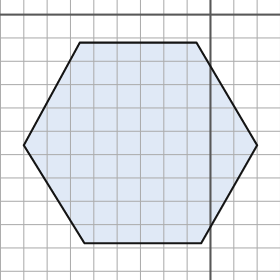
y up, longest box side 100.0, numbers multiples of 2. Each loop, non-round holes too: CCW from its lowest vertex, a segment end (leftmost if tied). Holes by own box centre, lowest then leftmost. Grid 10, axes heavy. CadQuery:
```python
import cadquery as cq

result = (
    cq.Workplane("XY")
    .moveTo(-54.0, -98.0)
    .lineTo(-4.0, -98.0)
    .lineTo(20.0, -56.0)
    .lineTo(-6.0, -12.0)
    .lineTo(-56.0, -12.0)
    .lineTo(-80.0, -56.0)
    .close()
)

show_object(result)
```